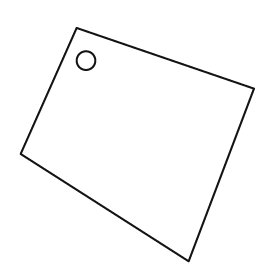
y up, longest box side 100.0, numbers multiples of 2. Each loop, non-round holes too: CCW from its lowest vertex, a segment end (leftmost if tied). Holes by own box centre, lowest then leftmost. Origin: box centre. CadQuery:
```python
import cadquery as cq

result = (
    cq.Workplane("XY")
    .moveTo(22.0, -50.0)
    .lineTo(50.0, 24.0)
    .lineTo(-26.0, 50.0)
    .lineTo(-50.0, -4.0)
    .close()
    .moveTo(-22.0, 36.0)
    .circle(4.0)
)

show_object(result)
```